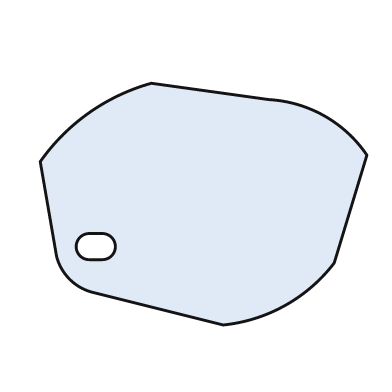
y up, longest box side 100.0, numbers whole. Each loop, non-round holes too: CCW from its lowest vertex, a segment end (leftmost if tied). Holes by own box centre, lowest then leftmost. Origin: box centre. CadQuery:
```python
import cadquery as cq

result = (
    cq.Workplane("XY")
    .moveTo(6.0, -37.0)
    .threePointArc((25.0, -31.0), (40.0, -18.0))
    .lineTo(50.0, 15.0)
    .threePointArc((37.0, 27.0), (20.0, 32.0))
    .lineTo(-16.0, 37.0)
    .threePointArc((-35.0, 28.0), (-50.0, 13.0))
    .lineTo(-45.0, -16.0)
    .threePointArc((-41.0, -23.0), (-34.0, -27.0))
    .close()
    .moveTo(-35.0, -17.0)
    .lineTo(-31.0, -17.0)
    .threePointArc((-27.0, -13.0), (-31.0, -9.0))
    .lineTo(-35.0, -9.0)
    .threePointArc((-39.0, -13.0), (-35.0, -17.0))
    .close()
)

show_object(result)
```